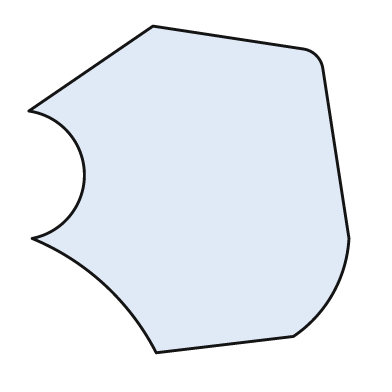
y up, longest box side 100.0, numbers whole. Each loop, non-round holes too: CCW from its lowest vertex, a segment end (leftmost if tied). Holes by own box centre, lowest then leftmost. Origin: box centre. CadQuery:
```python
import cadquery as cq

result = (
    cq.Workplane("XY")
    .moveTo(-10.0, -50.0)
    .lineTo(32.0, -45.0)
    .threePointArc((44.0, -32.0), (49.0, -15.0))
    .lineTo(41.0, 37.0)
    .threePointArc((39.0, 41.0), (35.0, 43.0))
    .lineTo(-11.0, 50.0)
    .lineTo(-49.0, 24.0)
    .threePointArc((-32.0, 5.0), (-48.0, -15.0))
    .threePointArc((-26.0, -29.0), (-10.0, -50.0))
    .close()
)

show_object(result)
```